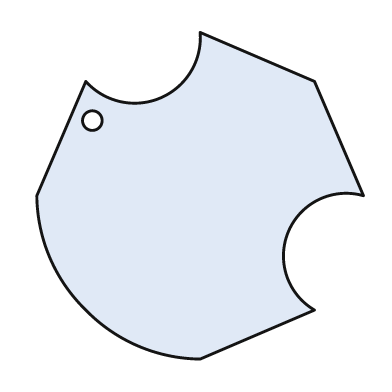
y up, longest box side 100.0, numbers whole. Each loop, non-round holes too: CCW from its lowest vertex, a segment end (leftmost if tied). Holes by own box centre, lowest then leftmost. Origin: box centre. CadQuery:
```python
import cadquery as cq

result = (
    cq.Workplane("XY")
    .moveTo(0.0, -50.0)
    .lineTo(35.0, -35.0)
    .threePointArc((27.0, -11.0), (50.0, 0.0))
    .lineTo(35.0, 35.0)
    .lineTo(0.0, 50.0)
    .threePointArc((-12.0, 30.0), (-35.0, 35.0))
    .lineTo(-50.0, 0.0)
    .threePointArc((-46.0, -19.0), (-35.0, -35.0))
    .threePointArc((-19.0, -46.0), (0.0, -50.0))
    .close()
    .moveTo(-33.0, 23.0)
    .circle(3.0)
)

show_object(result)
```